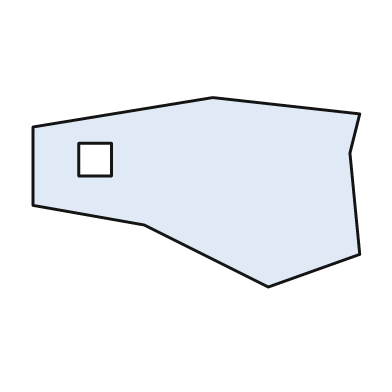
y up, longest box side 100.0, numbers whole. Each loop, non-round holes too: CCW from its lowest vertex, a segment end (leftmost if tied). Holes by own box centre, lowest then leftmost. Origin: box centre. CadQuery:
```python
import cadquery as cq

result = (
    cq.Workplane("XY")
    .moveTo(22.0, -29.0)
    .lineTo(50.0, -19.0)
    .lineTo(47.0, 12.0)
    .lineTo(50.0, 24.0)
    .lineTo(5.0, 29.0)
    .lineTo(-50.0, 20.0)
    .lineTo(-50.0, -4.0)
    .lineTo(-16.0, -10.0)
    .close()
    .moveTo(-36.0, 5.0)
    .lineTo(-26.0, 5.0)
    .lineTo(-26.0, 15.0)
    .lineTo(-36.0, 15.0)
    .close()
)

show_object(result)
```